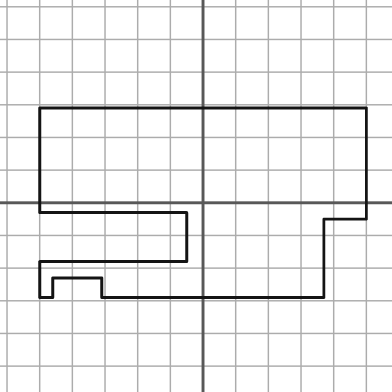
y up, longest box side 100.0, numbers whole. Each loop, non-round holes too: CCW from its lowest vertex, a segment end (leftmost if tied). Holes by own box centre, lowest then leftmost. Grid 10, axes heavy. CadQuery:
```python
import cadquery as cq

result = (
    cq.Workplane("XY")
    .moveTo(-50.0, -29.0)
    .lineTo(-46.0, -29.0)
    .lineTo(-46.0, -23.0)
    .lineTo(-31.0, -23.0)
    .lineTo(-31.0, -29.0)
    .lineTo(37.0, -29.0)
    .lineTo(37.0, -5.0)
    .lineTo(50.0, -5.0)
    .lineTo(50.0, 29.0)
    .lineTo(-50.0, 29.0)
    .lineTo(-50.0, -3.0)
    .lineTo(-5.0, -3.0)
    .lineTo(-5.0, -18.0)
    .lineTo(-50.0, -18.0)
    .close()
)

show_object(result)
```